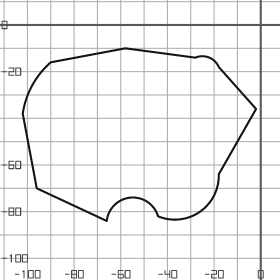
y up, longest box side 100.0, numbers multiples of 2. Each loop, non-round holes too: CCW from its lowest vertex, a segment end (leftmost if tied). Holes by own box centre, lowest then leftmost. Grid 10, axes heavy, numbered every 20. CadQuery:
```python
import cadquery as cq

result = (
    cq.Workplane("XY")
    .moveTo(-66.0, -84.0)
    .threePointArc((-56.0, -74.0), (-44.0, -82.0))
    .threePointArc((-26.0, -80.0), (-18.0, -64.0))
    .lineTo(-2.0, -36.0)
    .lineTo(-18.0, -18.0)
    .threePointArc((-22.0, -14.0), (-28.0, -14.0))
    .lineTo(-58.0, -10.0)
    .lineTo(-90.0, -16.0)
    .threePointArc((-98.0, -26.0), (-102.0, -38.0))
    .lineTo(-96.0, -70.0)
    .close()
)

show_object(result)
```